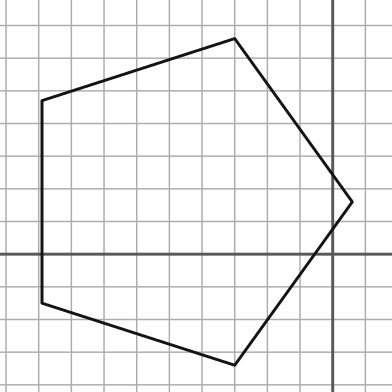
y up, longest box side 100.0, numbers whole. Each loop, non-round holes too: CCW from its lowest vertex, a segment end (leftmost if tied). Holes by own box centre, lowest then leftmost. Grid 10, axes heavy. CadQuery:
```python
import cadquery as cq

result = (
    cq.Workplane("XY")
    .moveTo(-30.0, -34.0)
    .lineTo(6.0, 16.0)
    .lineTo(-30.0, 66.0)
    .lineTo(-89.0, 47.0)
    .lineTo(-89.0, -15.0)
    .close()
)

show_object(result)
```